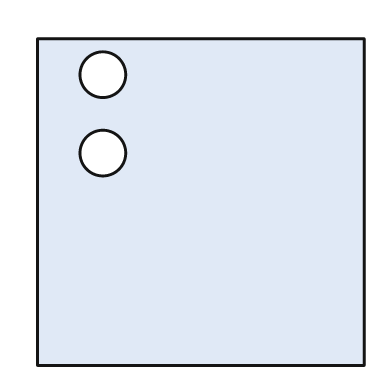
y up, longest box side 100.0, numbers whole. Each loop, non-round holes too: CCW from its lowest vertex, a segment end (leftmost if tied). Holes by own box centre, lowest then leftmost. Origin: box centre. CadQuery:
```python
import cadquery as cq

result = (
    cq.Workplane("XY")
    .moveTo(-50.0, -50.0)
    .lineTo(50.0, -50.0)
    .lineTo(50.0, 50.0)
    .lineTo(-50.0, 50.0)
    .close()
    .moveTo(-30.0, 15.0)
    .circle(7.0)
    .moveTo(-30.0, 39.0)
    .circle(7.0)
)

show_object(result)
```